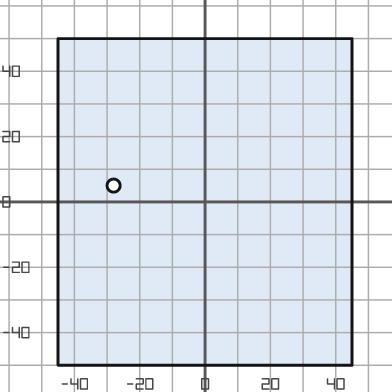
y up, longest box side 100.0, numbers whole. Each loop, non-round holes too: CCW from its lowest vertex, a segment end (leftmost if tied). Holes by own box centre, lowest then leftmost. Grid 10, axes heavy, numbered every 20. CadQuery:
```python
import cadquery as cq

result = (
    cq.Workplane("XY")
    .moveTo(-45.0, -50.0)
    .lineTo(45.0, -50.0)
    .lineTo(45.0, 50.0)
    .lineTo(-45.0, 50.0)
    .close()
    .moveTo(-28.0, 5.0)
    .circle(2.0)
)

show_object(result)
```